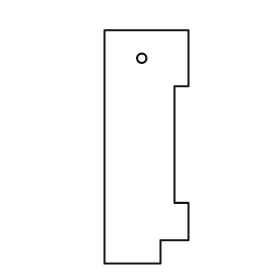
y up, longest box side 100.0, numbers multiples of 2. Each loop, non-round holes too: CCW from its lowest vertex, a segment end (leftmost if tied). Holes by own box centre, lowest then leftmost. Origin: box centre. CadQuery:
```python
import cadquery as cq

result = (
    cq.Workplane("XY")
    .moveTo(-18.0, -50.0)
    .lineTo(6.0, -50.0)
    .lineTo(6.0, -40.0)
    .lineTo(18.0, -40.0)
    .lineTo(18.0, -24.0)
    .lineTo(12.0, -24.0)
    .lineTo(12.0, 26.0)
    .lineTo(18.0, 26.0)
    .lineTo(18.0, 50.0)
    .lineTo(-18.0, 50.0)
    .close()
    .moveTo(-2.0, 38.0)
    .circle(2.0)
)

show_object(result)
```